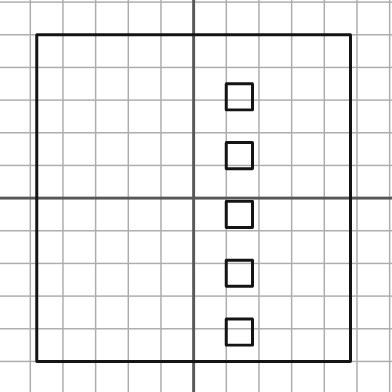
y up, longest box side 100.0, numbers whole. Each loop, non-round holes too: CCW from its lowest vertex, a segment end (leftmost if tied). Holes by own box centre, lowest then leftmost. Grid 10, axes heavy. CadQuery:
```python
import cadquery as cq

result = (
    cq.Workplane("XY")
    .moveTo(-48.0, -50.0)
    .lineTo(48.0, -50.0)
    .lineTo(48.0, 50.0)
    .lineTo(-48.0, 50.0)
    .close()
    .moveTo(10.0, -45.0)
    .lineTo(18.0, -45.0)
    .lineTo(18.0, -37.0)
    .lineTo(10.0, -37.0)
    .close()
    .moveTo(10.0, -27.0)
    .lineTo(18.0, -27.0)
    .lineTo(18.0, -19.0)
    .lineTo(10.0, -19.0)
    .close()
    .moveTo(10.0, -9.0)
    .lineTo(18.0, -9.0)
    .lineTo(18.0, -1.0)
    .lineTo(10.0, -1.0)
    .close()
    .moveTo(10.0, 9.0)
    .lineTo(18.0, 9.0)
    .lineTo(18.0, 17.0)
    .lineTo(10.0, 17.0)
    .close()
    .moveTo(10.0, 27.0)
    .lineTo(18.0, 27.0)
    .lineTo(18.0, 35.0)
    .lineTo(10.0, 35.0)
    .close()
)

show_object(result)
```